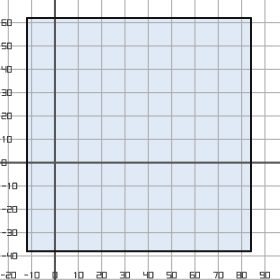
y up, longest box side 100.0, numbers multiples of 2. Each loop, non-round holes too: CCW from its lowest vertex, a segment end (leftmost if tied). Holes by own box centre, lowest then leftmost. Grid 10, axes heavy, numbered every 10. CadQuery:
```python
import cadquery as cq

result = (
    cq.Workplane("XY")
    .moveTo(-12.0, -38.0)
    .lineTo(84.0, -38.0)
    .lineTo(84.0, 62.0)
    .lineTo(-12.0, 62.0)
    .close()
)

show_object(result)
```